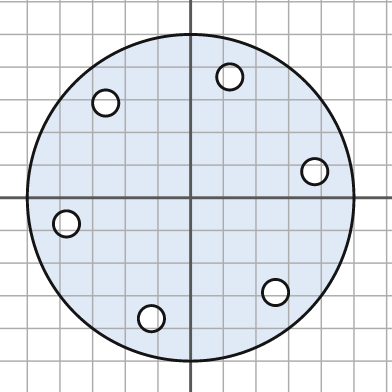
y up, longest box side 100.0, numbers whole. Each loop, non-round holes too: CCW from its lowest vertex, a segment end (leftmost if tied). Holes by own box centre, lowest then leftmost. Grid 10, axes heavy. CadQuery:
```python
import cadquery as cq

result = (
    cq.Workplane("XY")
    .moveTo(0.0, 0.0)
    .circle(50.0)
    .moveTo(-12.0, -37.0)
    .circle(4.0)
    .moveTo(26.0, -29.0)
    .circle(4.0)
    .moveTo(-38.0, -8.0)
    .circle(4.0)
    .moveTo(38.0, 8.0)
    .circle(4.0)
    .moveTo(-26.0, 29.0)
    .circle(4.0)
    .moveTo(12.0, 37.0)
    .circle(4.0)
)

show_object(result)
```